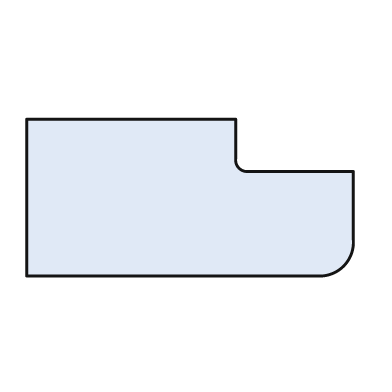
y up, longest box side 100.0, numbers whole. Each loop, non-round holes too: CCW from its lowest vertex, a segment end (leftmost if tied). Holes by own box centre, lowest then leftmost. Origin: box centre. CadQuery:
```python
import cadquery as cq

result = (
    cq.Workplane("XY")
    .moveTo(-50.0, -24.0)
    .lineTo(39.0, -24.0)
    .threePointArc((47.0, -21.0), (50.0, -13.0))
    .lineTo(50.0, 8.0)
    .lineTo(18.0, 8.0)
    .threePointArc((15.0, 9.0), (14.0, 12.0))
    .lineTo(14.0, 24.0)
    .lineTo(-50.0, 24.0)
    .close()
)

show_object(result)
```